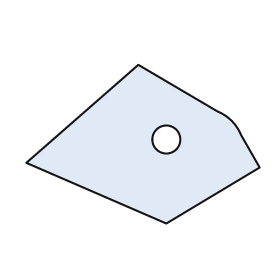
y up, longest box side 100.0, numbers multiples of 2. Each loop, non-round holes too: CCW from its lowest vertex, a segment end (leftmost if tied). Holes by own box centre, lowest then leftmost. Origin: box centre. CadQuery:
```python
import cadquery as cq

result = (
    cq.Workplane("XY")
    .moveTo(10.0, -34.0)
    .lineTo(50.0, -10.0)
    .lineTo(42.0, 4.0)
    .threePointArc((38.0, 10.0), (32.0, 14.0))
    .lineTo(-2.0, 34.0)
    .lineTo(-50.0, -8.0)
    .close()
    .moveTo(10.0, 2.0)
    .circle(6.0)
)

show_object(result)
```